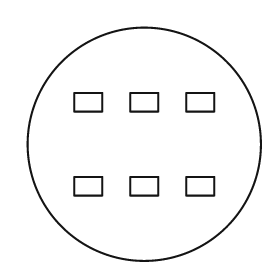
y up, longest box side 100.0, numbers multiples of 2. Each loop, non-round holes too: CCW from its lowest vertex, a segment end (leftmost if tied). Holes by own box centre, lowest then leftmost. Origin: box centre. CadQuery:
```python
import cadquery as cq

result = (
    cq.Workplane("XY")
    .moveTo(0.0, 0.0)
    .circle(50.0)
    .moveTo(-30.0, -22.0)
    .lineTo(-18.0, -22.0)
    .lineTo(-18.0, -14.0)
    .lineTo(-30.0, -14.0)
    .close()
    .moveTo(-6.0, -22.0)
    .lineTo(6.0, -22.0)
    .lineTo(6.0, -14.0)
    .lineTo(-6.0, -14.0)
    .close()
    .moveTo(18.0, -22.0)
    .lineTo(30.0, -22.0)
    .lineTo(30.0, -14.0)
    .lineTo(18.0, -14.0)
    .close()
    .moveTo(-30.0, 14.0)
    .lineTo(-18.0, 14.0)
    .lineTo(-18.0, 22.0)
    .lineTo(-30.0, 22.0)
    .close()
    .moveTo(-6.0, 14.0)
    .lineTo(6.0, 14.0)
    .lineTo(6.0, 22.0)
    .lineTo(-6.0, 22.0)
    .close()
    .moveTo(18.0, 14.0)
    .lineTo(30.0, 14.0)
    .lineTo(30.0, 22.0)
    .lineTo(18.0, 22.0)
    .close()
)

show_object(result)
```